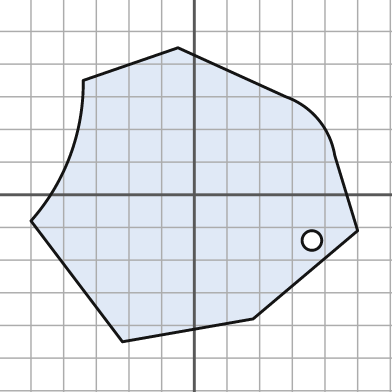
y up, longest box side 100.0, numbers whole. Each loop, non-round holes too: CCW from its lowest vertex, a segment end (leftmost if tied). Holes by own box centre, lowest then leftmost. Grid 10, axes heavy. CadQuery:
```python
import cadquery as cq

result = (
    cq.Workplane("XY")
    .moveTo(-22.0, -45.0)
    .lineTo(18.0, -38.0)
    .lineTo(50.0, -11.0)
    .lineTo(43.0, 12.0)
    .threePointArc((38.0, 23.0), (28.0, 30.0))
    .lineTo(-5.0, 45.0)
    .lineTo(-34.0, 35.0)
    .threePointArc((-38.0, 12.0), (-50.0, -8.0))
    .close()
    .moveTo(36.0, -14.0)
    .circle(3.0)
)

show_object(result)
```